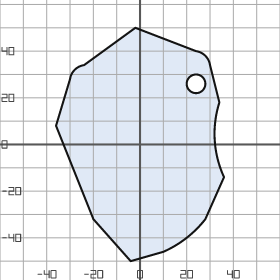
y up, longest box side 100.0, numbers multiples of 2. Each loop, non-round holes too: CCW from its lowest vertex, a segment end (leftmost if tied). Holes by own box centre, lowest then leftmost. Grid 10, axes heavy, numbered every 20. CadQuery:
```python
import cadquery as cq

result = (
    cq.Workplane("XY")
    .moveTo(-4.0, -50.0)
    .lineTo(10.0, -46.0)
    .threePointArc((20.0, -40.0), (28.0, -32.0))
    .lineTo(36.0, -14.0)
    .threePointArc((32.0, 2.0), (34.0, 18.0))
    .lineTo(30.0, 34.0)
    .threePointArc((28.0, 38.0), (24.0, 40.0))
    .lineTo(-2.0, 50.0)
    .lineTo(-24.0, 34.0)
    .threePointArc((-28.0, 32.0), (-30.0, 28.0))
    .lineTo(-36.0, 8.0)
    .lineTo(-20.0, -32.0)
    .close()
    .moveTo(24.0, 26.0)
    .circle(4.0)
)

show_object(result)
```